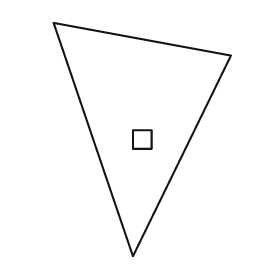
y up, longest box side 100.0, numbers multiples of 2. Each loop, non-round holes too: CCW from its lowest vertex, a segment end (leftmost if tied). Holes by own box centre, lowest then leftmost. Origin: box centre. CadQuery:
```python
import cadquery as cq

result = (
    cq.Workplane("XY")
    .moveTo(-4.0, -50.0)
    .lineTo(38.0, 36.0)
    .lineTo(-38.0, 50.0)
    .close()
    .moveTo(-4.0, -4.0)
    .lineTo(4.0, -4.0)
    .lineTo(4.0, 4.0)
    .lineTo(-4.0, 4.0)
    .close()
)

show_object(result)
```